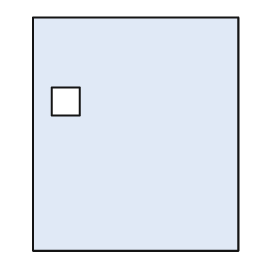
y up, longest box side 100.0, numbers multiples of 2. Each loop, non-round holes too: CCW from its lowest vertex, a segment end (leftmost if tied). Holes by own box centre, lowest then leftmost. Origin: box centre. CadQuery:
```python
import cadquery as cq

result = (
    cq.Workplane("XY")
    .moveTo(-44.0, -50.0)
    .lineTo(44.0, -50.0)
    .lineTo(44.0, 50.0)
    .lineTo(-44.0, 50.0)
    .close()
    .moveTo(-36.0, 8.0)
    .lineTo(-24.0, 8.0)
    .lineTo(-24.0, 20.0)
    .lineTo(-36.0, 20.0)
    .close()
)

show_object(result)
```